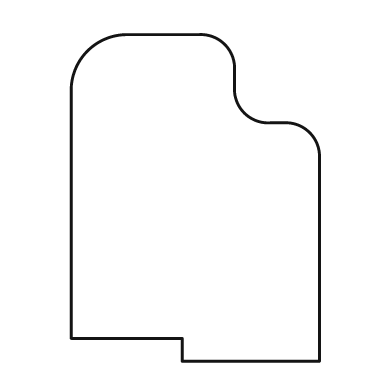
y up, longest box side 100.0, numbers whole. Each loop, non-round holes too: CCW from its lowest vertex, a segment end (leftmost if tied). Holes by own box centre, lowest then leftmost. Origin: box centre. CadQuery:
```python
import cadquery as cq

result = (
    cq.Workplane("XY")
    .moveTo(-4.0, -50.0)
    .lineTo(38.0, -50.0)
    .lineTo(38.0, 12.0)
    .threePointArc((35.0, 20.0), (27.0, 23.0))
    .lineTo(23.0, 23.0)
    .threePointArc((15.0, 26.0), (12.0, 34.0))
    .lineTo(12.0, 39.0)
    .threePointArc((9.0, 47.0), (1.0, 50.0))
    .lineTo(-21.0, 50.0)
    .threePointArc((-33.0, 45.0), (-38.0, 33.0))
    .lineTo(-38.0, -43.0)
    .lineTo(-4.0, -43.0)
    .close()
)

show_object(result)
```